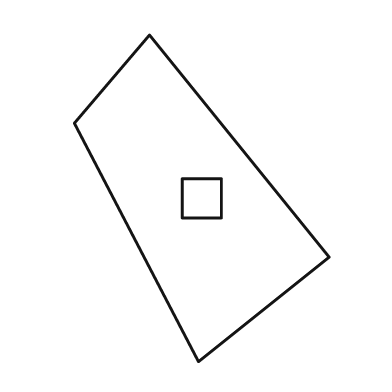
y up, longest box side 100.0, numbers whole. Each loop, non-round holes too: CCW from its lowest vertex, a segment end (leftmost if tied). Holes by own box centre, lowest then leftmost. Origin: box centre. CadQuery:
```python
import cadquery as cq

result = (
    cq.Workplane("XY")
    .moveTo(-1.0, -50.0)
    .lineTo(39.0, -18.0)
    .lineTo(-16.0, 50.0)
    .lineTo(-39.0, 23.0)
    .close()
    .moveTo(-6.0, -6.0)
    .lineTo(6.0, -6.0)
    .lineTo(6.0, 6.0)
    .lineTo(-6.0, 6.0)
    .close()
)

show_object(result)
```